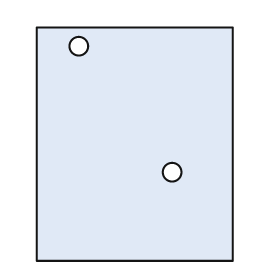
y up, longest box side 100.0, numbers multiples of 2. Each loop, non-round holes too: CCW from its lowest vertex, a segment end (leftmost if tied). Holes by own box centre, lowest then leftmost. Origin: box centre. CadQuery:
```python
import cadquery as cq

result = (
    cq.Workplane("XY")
    .moveTo(-42.0, -50.0)
    .lineTo(42.0, -50.0)
    .lineTo(42.0, 50.0)
    .lineTo(-42.0, 50.0)
    .close()
    .moveTo(16.0, -12.0)
    .circle(4.0)
    .moveTo(-24.0, 42.0)
    .circle(4.0)
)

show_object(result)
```